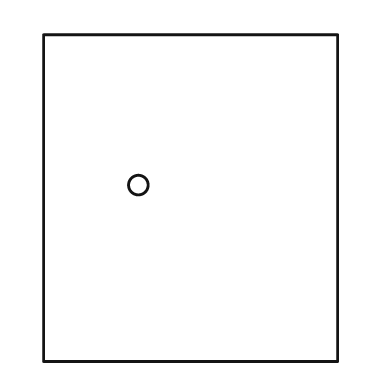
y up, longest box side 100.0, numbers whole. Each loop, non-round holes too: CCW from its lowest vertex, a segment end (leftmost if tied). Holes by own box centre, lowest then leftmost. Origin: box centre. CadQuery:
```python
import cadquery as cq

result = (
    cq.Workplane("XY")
    .moveTo(-45.0, -50.0)
    .lineTo(45.0, -50.0)
    .lineTo(45.0, 50.0)
    .lineTo(-45.0, 50.0)
    .close()
    .moveTo(-16.0, 4.0)
    .circle(3.0)
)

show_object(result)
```